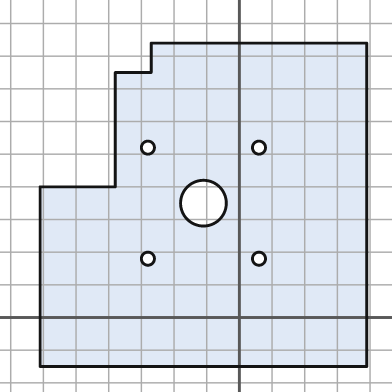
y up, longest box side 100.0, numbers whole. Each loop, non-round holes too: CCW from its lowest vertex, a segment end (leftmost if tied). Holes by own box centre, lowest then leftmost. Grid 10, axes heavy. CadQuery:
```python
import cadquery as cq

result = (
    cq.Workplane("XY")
    .moveTo(-61.0, -15.0)
    .lineTo(39.0, -15.0)
    .lineTo(39.0, 84.0)
    .lineTo(-27.0, 84.0)
    .lineTo(-27.0, 75.0)
    .lineTo(-38.0, 75.0)
    .lineTo(-38.0, 40.0)
    .lineTo(-61.0, 40.0)
    .close()
    .moveTo(-28.0, 18.0)
    .circle(2.0)
    .moveTo(6.0, 18.0)
    .circle(2.0)
    .moveTo(-11.0, 35.0)
    .circle(7.0)
    .moveTo(-28.0, 52.0)
    .circle(2.0)
    .moveTo(6.0, 52.0)
    .circle(2.0)
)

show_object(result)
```